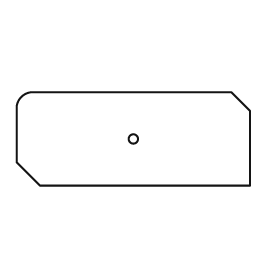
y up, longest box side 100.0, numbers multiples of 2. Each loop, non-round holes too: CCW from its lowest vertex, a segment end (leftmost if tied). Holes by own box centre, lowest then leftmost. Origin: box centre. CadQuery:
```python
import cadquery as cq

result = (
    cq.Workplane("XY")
    .moveTo(-40.0, -20.0)
    .lineTo(50.0, -20.0)
    .lineTo(50.0, 12.0)
    .lineTo(42.0, 20.0)
    .lineTo(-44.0, 20.0)
    .threePointArc((-48.0, 18.0), (-50.0, 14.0))
    .lineTo(-50.0, -10.0)
    .close()
    .moveTo(0.0, 0.0)
    .circle(2.0)
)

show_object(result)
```